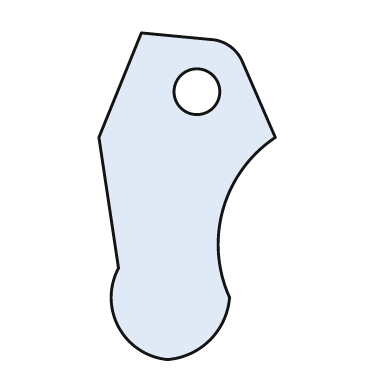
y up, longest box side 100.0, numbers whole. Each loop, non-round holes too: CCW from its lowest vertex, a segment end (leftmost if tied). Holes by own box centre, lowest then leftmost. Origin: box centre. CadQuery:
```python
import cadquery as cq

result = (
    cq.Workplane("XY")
    .moveTo(-6.0, -50.0)
    .threePointArc((7.0, -44.0), (13.0, -31.0))
    .threePointArc((11.0, -4.0), (27.0, 18.0))
    .lineTo(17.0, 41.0)
    .threePointArc((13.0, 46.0), (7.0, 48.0))
    .lineTo(-14.0, 50.0)
    .lineTo(-27.0, 18.0)
    .lineTo(-21.0, -22.0)
    .threePointArc((-21.0, -40.0), (-6.0, -50.0))
    .close()
    .moveTo(3.0, 32.0)
    .circle(7.0)
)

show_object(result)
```